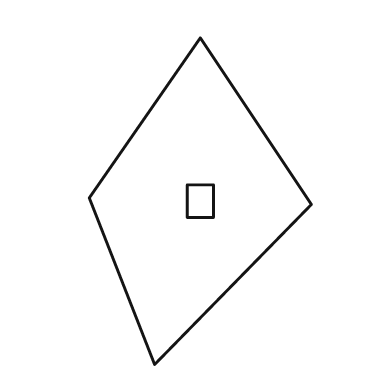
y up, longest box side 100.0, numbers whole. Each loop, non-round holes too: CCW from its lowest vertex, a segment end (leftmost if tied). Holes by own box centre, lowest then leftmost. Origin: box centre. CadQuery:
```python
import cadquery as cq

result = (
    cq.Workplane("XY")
    .moveTo(-14.0, -50.0)
    .lineTo(34.0, -1.0)
    .lineTo(0.0, 50.0)
    .lineTo(-34.0, 1.0)
    .close()
    .moveTo(-4.0, -5.0)
    .lineTo(4.0, -5.0)
    .lineTo(4.0, 5.0)
    .lineTo(-4.0, 5.0)
    .close()
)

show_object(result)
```